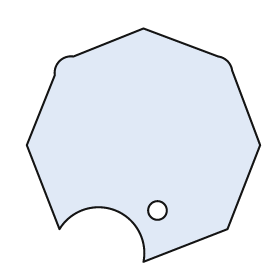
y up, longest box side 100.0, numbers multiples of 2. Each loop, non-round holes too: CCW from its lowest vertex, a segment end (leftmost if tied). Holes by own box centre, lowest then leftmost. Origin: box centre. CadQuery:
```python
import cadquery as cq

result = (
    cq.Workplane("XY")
    .moveTo(0.0, -50.0)
    .lineTo(36.0, -36.0)
    .lineTo(50.0, 0.0)
    .lineTo(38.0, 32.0)
    .threePointArc((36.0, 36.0), (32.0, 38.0))
    .lineTo(0.0, 50.0)
    .lineTo(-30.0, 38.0)
    .threePointArc((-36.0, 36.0), (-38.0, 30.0))
    .lineTo(-50.0, 0.0)
    .lineTo(-36.0, -36.0)
    .threePointArc((-12.0, -28.0), (0.0, -50.0))
    .close()
    .moveTo(6.0, -28.0)
    .circle(4.0)
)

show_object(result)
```